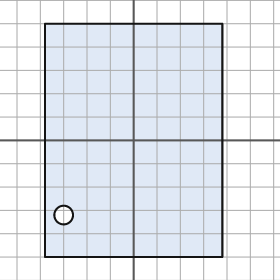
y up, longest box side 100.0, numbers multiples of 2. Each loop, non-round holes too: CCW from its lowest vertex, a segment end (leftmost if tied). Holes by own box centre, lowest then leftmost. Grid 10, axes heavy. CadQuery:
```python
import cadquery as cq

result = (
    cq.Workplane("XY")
    .moveTo(-38.0, -50.0)
    .lineTo(38.0, -50.0)
    .lineTo(38.0, 50.0)
    .lineTo(-38.0, 50.0)
    .close()
    .moveTo(-30.0, -32.0)
    .circle(4.0)
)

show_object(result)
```